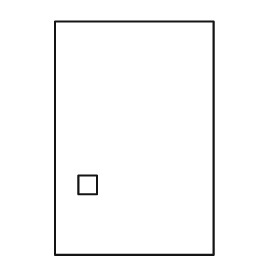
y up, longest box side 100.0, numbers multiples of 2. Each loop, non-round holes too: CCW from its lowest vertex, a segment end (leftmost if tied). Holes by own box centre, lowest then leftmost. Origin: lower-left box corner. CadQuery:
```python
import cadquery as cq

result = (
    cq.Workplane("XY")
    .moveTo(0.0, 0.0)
    .lineTo(68.0, 0.0)
    .lineTo(68.0, 100.0)
    .lineTo(0.0, 100.0)
    .close()
    .moveTo(10.0, 26.0)
    .lineTo(18.0, 26.0)
    .lineTo(18.0, 34.0)
    .lineTo(10.0, 34.0)
    .close()
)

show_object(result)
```